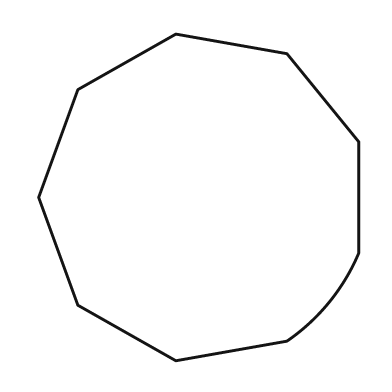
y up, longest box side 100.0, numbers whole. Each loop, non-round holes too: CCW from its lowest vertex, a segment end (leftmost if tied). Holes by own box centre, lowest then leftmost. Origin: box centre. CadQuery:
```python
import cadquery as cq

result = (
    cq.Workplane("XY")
    .moveTo(-7.0, -50.0)
    .lineTo(27.0, -44.0)
    .threePointArc((40.0, -32.0), (49.0, -17.0))
    .lineTo(49.0, 17.0)
    .lineTo(27.0, 44.0)
    .lineTo(-7.0, 50.0)
    .lineTo(-37.0, 33.0)
    .lineTo(-49.0, 0.0)
    .lineTo(-37.0, -33.0)
    .close()
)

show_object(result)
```